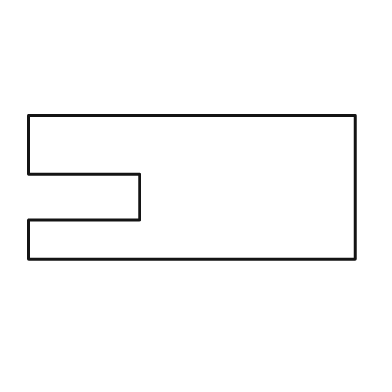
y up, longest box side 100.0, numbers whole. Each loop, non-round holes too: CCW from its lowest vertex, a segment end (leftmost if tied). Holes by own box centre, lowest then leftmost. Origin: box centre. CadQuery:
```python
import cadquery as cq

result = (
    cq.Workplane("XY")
    .moveTo(-50.0, -22.0)
    .lineTo(50.0, -22.0)
    .lineTo(50.0, 22.0)
    .lineTo(-50.0, 22.0)
    .lineTo(-50.0, 4.0)
    .lineTo(-16.0, 4.0)
    .lineTo(-16.0, -10.0)
    .lineTo(-50.0, -10.0)
    .close()
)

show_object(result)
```